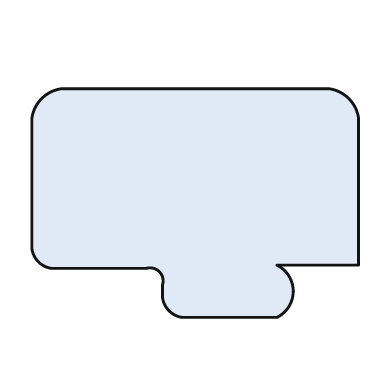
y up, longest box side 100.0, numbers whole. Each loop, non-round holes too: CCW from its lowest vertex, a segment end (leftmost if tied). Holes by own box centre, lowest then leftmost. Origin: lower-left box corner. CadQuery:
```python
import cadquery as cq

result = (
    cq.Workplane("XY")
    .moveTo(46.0, 0.0)
    .lineTo(75.0, 0.0)
    .threePointArc((80.0, 8.0), (75.0, 16.0))
    .lineTo(100.0, 16.0)
    .lineTo(100.0, 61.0)
    .threePointArc((97.0, 67.0), (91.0, 70.0))
    .lineTo(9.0, 70.0)
    .threePointArc((3.0, 67.0), (0.0, 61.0))
    .lineTo(0.0, 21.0)
    .threePointArc((2.0, 17.0), (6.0, 15.0))
    .lineTo(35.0, 15.0)
    .threePointArc((39.0, 14.0), (40.0, 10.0))
    .lineTo(40.0, 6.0)
    .threePointArc((42.0, 2.0), (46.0, 0.0))
    .close()
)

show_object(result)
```